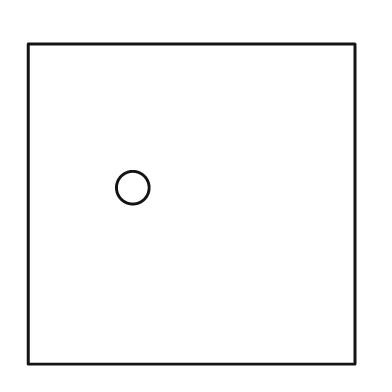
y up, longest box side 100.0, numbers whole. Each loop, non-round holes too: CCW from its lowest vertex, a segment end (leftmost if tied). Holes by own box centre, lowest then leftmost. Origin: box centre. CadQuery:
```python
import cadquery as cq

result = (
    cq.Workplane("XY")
    .moveTo(-50.0, -49.0)
    .lineTo(50.0, -49.0)
    .lineTo(50.0, 49.0)
    .lineTo(-50.0, 49.0)
    .close()
    .moveTo(-18.0, 5.0)
    .circle(5.0)
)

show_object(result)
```